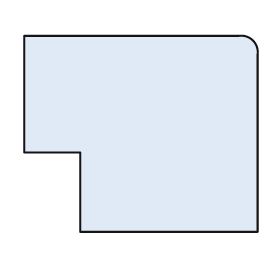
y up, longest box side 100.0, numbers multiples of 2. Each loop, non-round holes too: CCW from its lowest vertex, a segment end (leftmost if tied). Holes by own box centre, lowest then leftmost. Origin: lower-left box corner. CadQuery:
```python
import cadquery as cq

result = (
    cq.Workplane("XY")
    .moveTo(24.0, 0.0)
    .lineTo(100.0, 0.0)
    .lineTo(100.0, 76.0)
    .threePointArc((98.0, 82.0), (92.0, 84.0))
    .lineTo(0.0, 84.0)
    .lineTo(0.0, 34.0)
    .lineTo(24.0, 34.0)
    .close()
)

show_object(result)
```